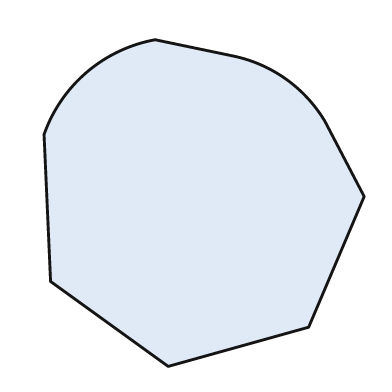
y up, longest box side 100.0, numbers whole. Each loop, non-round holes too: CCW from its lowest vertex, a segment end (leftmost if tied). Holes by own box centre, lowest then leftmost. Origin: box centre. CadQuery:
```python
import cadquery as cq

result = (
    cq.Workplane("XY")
    .moveTo(-11.0, -50.0)
    .lineTo(32.0, -38.0)
    .lineTo(49.0, 2.0)
    .lineTo(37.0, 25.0)
    .threePointArc((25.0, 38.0), (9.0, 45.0))
    .lineTo(-15.0, 50.0)
    .threePointArc((-36.0, 40.0), (-49.0, 21.0))
    .lineTo(-47.0, -24.0)
    .close()
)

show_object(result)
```